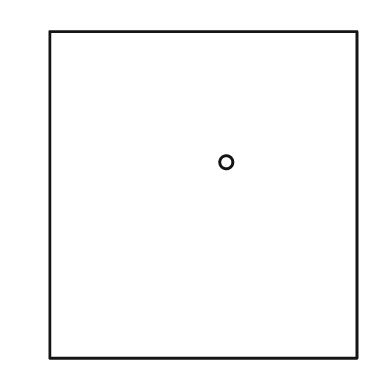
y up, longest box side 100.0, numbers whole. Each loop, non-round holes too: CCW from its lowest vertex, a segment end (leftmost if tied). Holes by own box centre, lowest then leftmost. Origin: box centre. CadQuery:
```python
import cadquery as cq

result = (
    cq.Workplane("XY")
    .moveTo(-47.0, -50.0)
    .lineTo(47.0, -50.0)
    .lineTo(47.0, 50.0)
    .lineTo(-47.0, 50.0)
    .close()
    .moveTo(7.0, 10.0)
    .circle(2.0)
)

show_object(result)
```